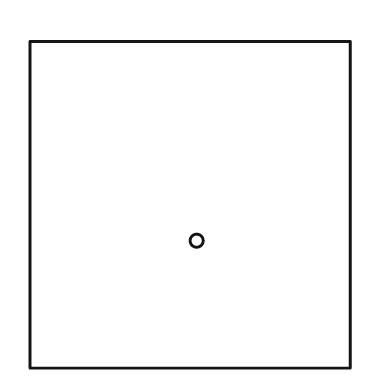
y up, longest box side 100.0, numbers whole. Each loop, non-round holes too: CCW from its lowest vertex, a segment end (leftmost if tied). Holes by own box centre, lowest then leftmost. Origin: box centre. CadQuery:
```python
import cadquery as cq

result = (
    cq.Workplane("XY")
    .moveTo(-49.0, -50.0)
    .lineTo(49.0, -50.0)
    .lineTo(49.0, 50.0)
    .lineTo(-49.0, 50.0)
    .close()
    .moveTo(2.0, -11.0)
    .circle(2.0)
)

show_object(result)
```